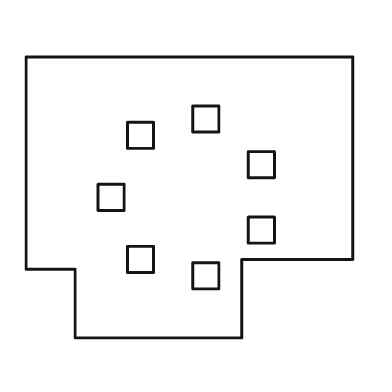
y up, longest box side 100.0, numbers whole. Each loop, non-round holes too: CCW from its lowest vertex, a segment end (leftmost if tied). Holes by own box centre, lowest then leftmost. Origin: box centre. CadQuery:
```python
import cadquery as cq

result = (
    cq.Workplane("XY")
    .moveTo(-35.0, -43.0)
    .lineTo(16.0, -43.0)
    .lineTo(16.0, -19.0)
    .lineTo(50.0, -19.0)
    .lineTo(50.0, 43.0)
    .lineTo(-50.0, 43.0)
    .lineTo(-50.0, -22.0)
    .lineTo(-35.0, -22.0)
    .close()
    .moveTo(1.0, -28.0)
    .lineTo(9.0, -28.0)
    .lineTo(9.0, -20.0)
    .lineTo(1.0, -20.0)
    .close()
    .moveTo(-19.0, -23.0)
    .lineTo(-11.0, -23.0)
    .lineTo(-11.0, -15.0)
    .lineTo(-19.0, -15.0)
    .close()
    .moveTo(18.0, -14.0)
    .lineTo(26.0, -14.0)
    .lineTo(26.0, -6.0)
    .lineTo(18.0, -6.0)
    .close()
    .moveTo(-28.0, -4.0)
    .lineTo(-20.0, -4.0)
    .lineTo(-20.0, 4.0)
    .lineTo(-28.0, 4.0)
    .close()
    .moveTo(18.0, 6.0)
    .lineTo(26.0, 6.0)
    .lineTo(26.0, 14.0)
    .lineTo(18.0, 14.0)
    .close()
    .moveTo(-19.0, 15.0)
    .lineTo(-11.0, 15.0)
    .lineTo(-11.0, 23.0)
    .lineTo(-19.0, 23.0)
    .close()
    .moveTo(1.0, 20.0)
    .lineTo(9.0, 20.0)
    .lineTo(9.0, 28.0)
    .lineTo(1.0, 28.0)
    .close()
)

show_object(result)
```